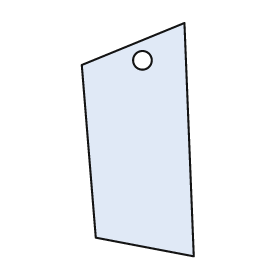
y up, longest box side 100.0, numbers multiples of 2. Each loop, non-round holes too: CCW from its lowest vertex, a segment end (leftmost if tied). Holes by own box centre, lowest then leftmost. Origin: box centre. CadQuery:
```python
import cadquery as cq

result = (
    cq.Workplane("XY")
    .moveTo(24.0, -50.0)
    .lineTo(20.0, 50.0)
    .lineTo(-24.0, 32.0)
    .lineTo(-18.0, -42.0)
    .close()
    .moveTo(2.0, 34.0)
    .circle(4.0)
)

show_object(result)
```